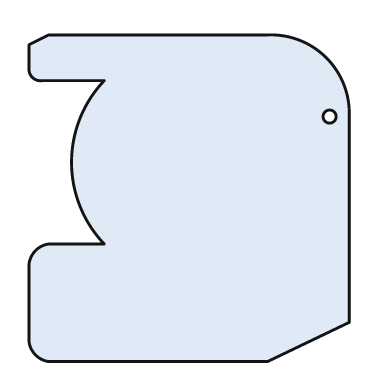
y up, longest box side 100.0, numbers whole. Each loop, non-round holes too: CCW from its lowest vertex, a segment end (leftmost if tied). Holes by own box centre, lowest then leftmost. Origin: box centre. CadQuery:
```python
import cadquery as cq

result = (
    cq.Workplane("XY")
    .moveTo(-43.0, -50.0)
    .lineTo(24.0, -50.0)
    .lineTo(49.0, -38.0)
    .lineTo(49.0, 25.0)
    .threePointArc((42.0, 43.0), (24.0, 50.0))
    .lineTo(-43.0, 50.0)
    .lineTo(-49.0, 47.0)
    .lineTo(-49.0, 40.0)
    .threePointArc((-48.0, 37.0), (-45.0, 36.0))
    .lineTo(-26.0, 36.0)
    .threePointArc((-36.0, 11.0), (-26.0, -14.0))
    .lineTo(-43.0, -14.0)
    .threePointArc((-47.0, -16.0), (-49.0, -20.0))
    .lineTo(-49.0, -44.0)
    .threePointArc((-47.0, -48.0), (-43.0, -50.0))
    .close()
    .moveTo(43.0, 25.0)
    .circle(2.0)
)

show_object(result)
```